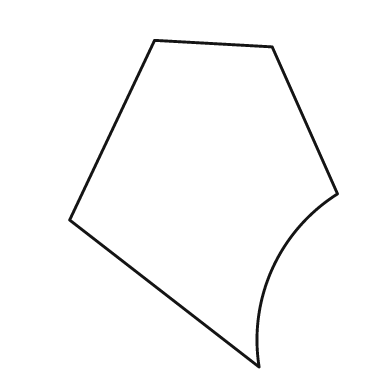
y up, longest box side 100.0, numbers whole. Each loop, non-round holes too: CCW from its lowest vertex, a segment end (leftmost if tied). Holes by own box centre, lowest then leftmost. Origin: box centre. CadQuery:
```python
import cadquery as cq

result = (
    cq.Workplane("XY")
    .moveTo(17.0, -50.0)
    .threePointArc((21.0, -20.0), (41.0, 3.0))
    .lineTo(21.0, 48.0)
    .lineTo(-15.0, 50.0)
    .lineTo(-41.0, -5.0)
    .close()
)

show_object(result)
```